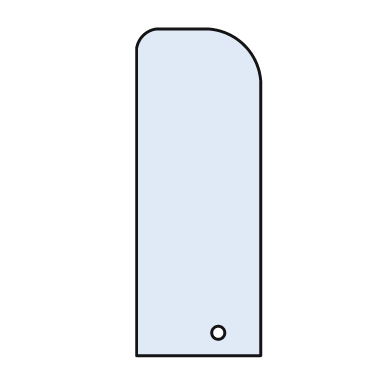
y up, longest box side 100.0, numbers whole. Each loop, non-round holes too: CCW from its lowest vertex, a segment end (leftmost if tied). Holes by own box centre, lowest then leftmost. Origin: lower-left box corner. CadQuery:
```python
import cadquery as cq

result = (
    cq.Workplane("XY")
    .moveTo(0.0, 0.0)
    .lineTo(38.0, 0.0)
    .lineTo(38.0, 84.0)
    .threePointArc((33.0, 95.0), (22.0, 100.0))
    .lineTo(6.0, 100.0)
    .threePointArc((2.0, 98.0), (0.0, 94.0))
    .close()
    .moveTo(25.0, 7.0)
    .circle(2.0)
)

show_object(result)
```